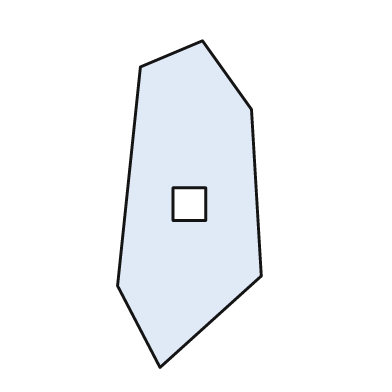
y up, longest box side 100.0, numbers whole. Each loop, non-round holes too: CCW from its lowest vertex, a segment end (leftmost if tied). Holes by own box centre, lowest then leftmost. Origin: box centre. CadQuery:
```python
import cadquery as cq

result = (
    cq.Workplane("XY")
    .moveTo(-9.0, -50.0)
    .lineTo(22.0, -22.0)
    .lineTo(19.0, 29.0)
    .lineTo(4.0, 50.0)
    .lineTo(-15.0, 42.0)
    .lineTo(-22.0, -25.0)
    .close()
    .moveTo(-5.0, -5.0)
    .lineTo(5.0, -5.0)
    .lineTo(5.0, 5.0)
    .lineTo(-5.0, 5.0)
    .close()
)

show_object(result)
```